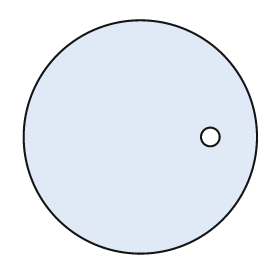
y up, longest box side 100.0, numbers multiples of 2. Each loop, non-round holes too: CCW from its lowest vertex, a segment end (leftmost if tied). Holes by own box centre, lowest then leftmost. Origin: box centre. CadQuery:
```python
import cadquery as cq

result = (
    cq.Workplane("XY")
    .moveTo(0.0, 0.0)
    .circle(50.0)
    .moveTo(30.0, 0.0)
    .circle(4.0)
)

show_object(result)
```